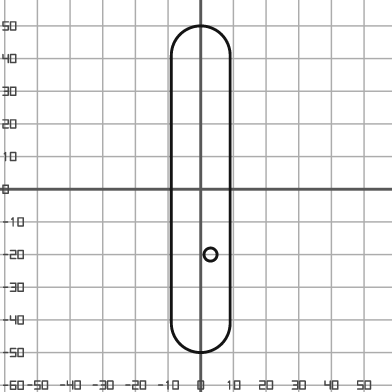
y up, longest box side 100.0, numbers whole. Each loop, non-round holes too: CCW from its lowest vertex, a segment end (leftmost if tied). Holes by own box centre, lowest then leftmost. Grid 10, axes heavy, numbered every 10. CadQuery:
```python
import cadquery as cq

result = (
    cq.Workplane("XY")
    .moveTo(-9.0, -41.0)
    .threePointArc((0.0, -50.0), (9.0, -41.0))
    .lineTo(9.0, 41.0)
    .threePointArc((0.0, 50.0), (-9.0, 41.0))
    .close()
    .moveTo(3.0, -20.0)
    .circle(2.0)
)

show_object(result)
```